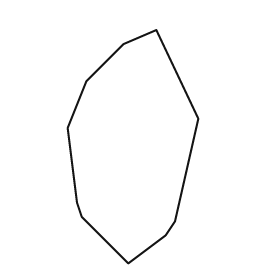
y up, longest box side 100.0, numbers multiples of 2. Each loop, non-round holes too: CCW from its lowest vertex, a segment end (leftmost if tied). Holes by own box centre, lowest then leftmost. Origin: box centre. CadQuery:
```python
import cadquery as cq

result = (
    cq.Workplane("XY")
    .moveTo(-2.0, -50.0)
    .lineTo(14.0, -38.0)
    .lineTo(18.0, -32.0)
    .lineTo(28.0, 12.0)
    .lineTo(10.0, 50.0)
    .lineTo(-4.0, 44.0)
    .lineTo(-20.0, 28.0)
    .lineTo(-28.0, 8.0)
    .lineTo(-24.0, -24.0)
    .lineTo(-22.0, -30.0)
    .close()
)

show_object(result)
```